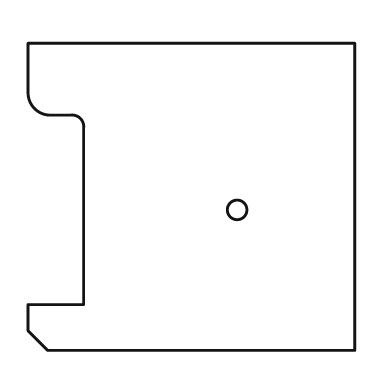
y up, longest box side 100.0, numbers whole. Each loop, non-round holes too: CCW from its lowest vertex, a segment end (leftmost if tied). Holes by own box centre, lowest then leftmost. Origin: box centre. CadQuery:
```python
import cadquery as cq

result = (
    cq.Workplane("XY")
    .moveTo(-44.0, -47.0)
    .lineTo(50.0, -47.0)
    .lineTo(50.0, 47.0)
    .lineTo(-50.0, 47.0)
    .lineTo(-50.0, 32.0)
    .threePointArc((-48.0, 27.0), (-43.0, 25.0))
    .lineTo(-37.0, 25.0)
    .threePointArc((-34.0, 24.0), (-33.0, 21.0))
    .lineTo(-33.0, -33.0)
    .lineTo(-50.0, -33.0)
    .lineTo(-50.0, -41.0)
    .close()
    .moveTo(14.0, -4.0)
    .circle(3.0)
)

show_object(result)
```